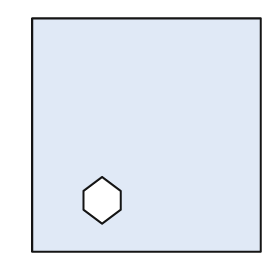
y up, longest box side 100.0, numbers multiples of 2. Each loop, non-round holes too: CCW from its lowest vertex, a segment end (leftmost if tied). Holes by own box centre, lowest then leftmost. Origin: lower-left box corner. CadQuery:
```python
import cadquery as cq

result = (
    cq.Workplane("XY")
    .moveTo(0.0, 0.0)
    .lineTo(98.0, 0.0)
    .lineTo(98.0, 100.0)
    .lineTo(0.0, 100.0)
    .close()
    .moveTo(30.0, 12.0)
    .lineTo(38.0, 18.0)
    .lineTo(38.0, 26.0)
    .lineTo(30.0, 32.0)
    .lineTo(22.0, 26.0)
    .lineTo(22.0, 18.0)
    .close()
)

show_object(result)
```